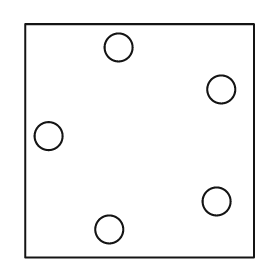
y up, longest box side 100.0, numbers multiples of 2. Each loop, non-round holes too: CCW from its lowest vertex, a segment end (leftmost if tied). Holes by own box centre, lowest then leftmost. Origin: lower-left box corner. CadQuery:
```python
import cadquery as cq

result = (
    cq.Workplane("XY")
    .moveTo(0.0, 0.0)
    .lineTo(98.0, 0.0)
    .lineTo(98.0, 100.0)
    .lineTo(0.0, 100.0)
    .close()
    .moveTo(36.0, 12.0)
    .circle(6.0)
    .moveTo(82.0, 24.0)
    .circle(6.0)
    .moveTo(10.0, 52.0)
    .circle(6.0)
    .moveTo(84.0, 72.0)
    .circle(6.0)
    .moveTo(40.0, 90.0)
    .circle(6.0)
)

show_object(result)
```